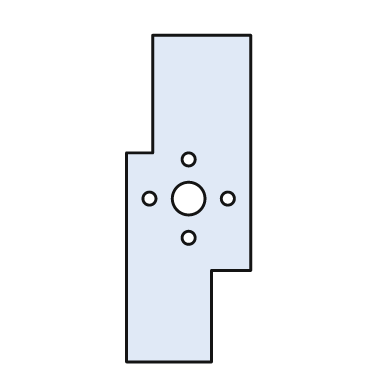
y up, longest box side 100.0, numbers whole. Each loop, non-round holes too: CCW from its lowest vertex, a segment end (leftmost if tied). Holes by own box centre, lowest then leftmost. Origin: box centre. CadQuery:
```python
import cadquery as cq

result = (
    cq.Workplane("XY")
    .moveTo(-19.0, -50.0)
    .lineTo(7.0, -50.0)
    .lineTo(7.0, -22.0)
    .lineTo(19.0, -22.0)
    .lineTo(19.0, 50.0)
    .lineTo(-11.0, 50.0)
    .lineTo(-11.0, 14.0)
    .lineTo(-19.0, 14.0)
    .close()
    .moveTo(0.0, -12.0)
    .circle(2.0)
    .moveTo(-12.0, 0.0)
    .circle(2.0)
    .moveTo(0.0, 0.0)
    .circle(5.0)
    .moveTo(12.0, 0.0)
    .circle(2.0)
    .moveTo(0.0, 12.0)
    .circle(2.0)
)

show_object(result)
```